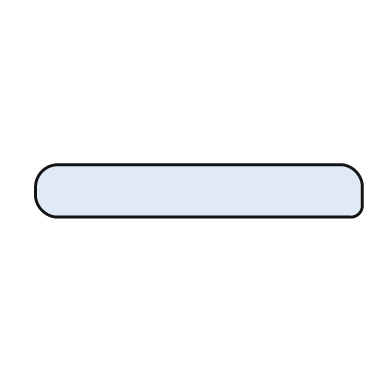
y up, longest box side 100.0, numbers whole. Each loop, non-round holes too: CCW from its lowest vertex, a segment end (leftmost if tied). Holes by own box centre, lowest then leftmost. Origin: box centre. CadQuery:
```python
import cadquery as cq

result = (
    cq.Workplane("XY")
    .moveTo(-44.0, -8.0)
    .lineTo(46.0, -8.0)
    .threePointArc((49.0, -7.0), (50.0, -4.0))
    .lineTo(50.0, 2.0)
    .threePointArc((48.0, 6.0), (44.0, 8.0))
    .lineTo(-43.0, 8.0)
    .threePointArc((-48.0, 6.0), (-50.0, 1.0))
    .lineTo(-50.0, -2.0)
    .threePointArc((-48.0, -6.0), (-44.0, -8.0))
    .close()
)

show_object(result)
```